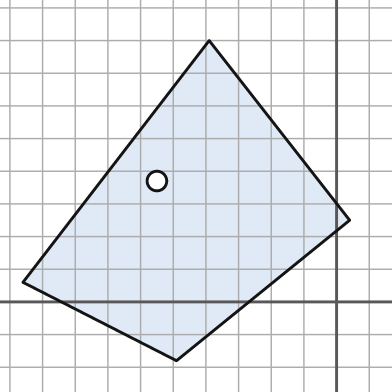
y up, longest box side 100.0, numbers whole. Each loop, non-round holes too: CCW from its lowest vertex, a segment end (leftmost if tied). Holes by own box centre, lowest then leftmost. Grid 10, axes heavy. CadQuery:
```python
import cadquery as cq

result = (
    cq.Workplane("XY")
    .moveTo(-49.0, -18.0)
    .lineTo(4.0, 25.0)
    .lineTo(-39.0, 80.0)
    .lineTo(-96.0, 6.0)
    .close()
    .moveTo(-55.0, 37.0)
    .circle(3.0)
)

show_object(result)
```